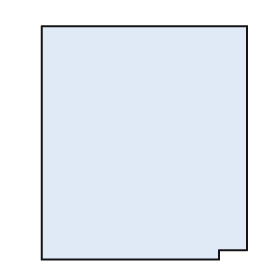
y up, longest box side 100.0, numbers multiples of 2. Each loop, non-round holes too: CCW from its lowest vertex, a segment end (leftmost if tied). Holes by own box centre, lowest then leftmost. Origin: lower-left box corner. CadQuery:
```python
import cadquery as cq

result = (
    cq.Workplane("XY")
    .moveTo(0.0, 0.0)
    .lineTo(76.0, 0.0)
    .lineTo(76.0, 4.0)
    .lineTo(88.0, 4.0)
    .lineTo(88.0, 100.0)
    .lineTo(0.0, 100.0)
    .close()
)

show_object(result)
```